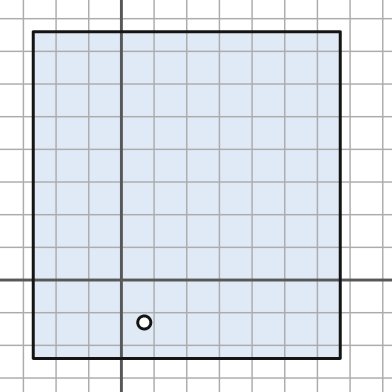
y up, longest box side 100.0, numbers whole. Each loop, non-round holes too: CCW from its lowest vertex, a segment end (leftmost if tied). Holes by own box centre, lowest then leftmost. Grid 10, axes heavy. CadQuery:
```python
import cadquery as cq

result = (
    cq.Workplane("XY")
    .moveTo(-27.0, -24.0)
    .lineTo(67.0, -24.0)
    .lineTo(67.0, 76.0)
    .lineTo(-27.0, 76.0)
    .close()
    .moveTo(7.0, -13.0)
    .circle(2.0)
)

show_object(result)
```